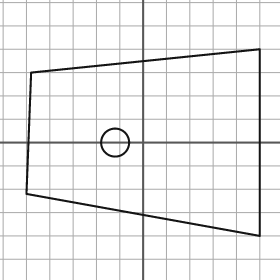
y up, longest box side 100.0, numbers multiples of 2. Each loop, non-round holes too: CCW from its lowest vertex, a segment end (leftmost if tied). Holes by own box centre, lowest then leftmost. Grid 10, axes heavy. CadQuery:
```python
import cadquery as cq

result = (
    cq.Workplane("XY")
    .moveTo(50.0, -40.0)
    .lineTo(50.0, 40.0)
    .lineTo(-48.0, 30.0)
    .lineTo(-50.0, -22.0)
    .close()
    .moveTo(-12.0, 0.0)
    .circle(6.0)
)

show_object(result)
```